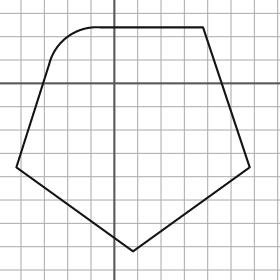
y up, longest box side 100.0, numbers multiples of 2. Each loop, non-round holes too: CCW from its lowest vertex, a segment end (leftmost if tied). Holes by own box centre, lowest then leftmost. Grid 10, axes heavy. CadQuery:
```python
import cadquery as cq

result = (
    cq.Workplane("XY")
    .moveTo(8.0, -72.0)
    .lineTo(58.0, -36.0)
    .lineTo(38.0, 24.0)
    .lineTo(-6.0, 24.0)
    .threePointArc((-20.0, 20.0), (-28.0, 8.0))
    .lineTo(-42.0, -36.0)
    .close()
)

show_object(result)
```